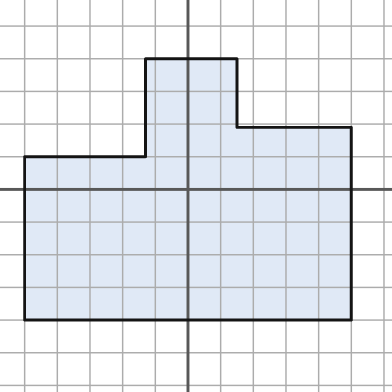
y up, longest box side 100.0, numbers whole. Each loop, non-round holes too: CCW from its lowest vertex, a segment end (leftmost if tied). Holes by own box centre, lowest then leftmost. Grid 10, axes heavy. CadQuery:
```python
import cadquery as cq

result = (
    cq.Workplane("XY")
    .moveTo(-50.0, -40.0)
    .lineTo(50.0, -40.0)
    .lineTo(50.0, 19.0)
    .lineTo(15.0, 19.0)
    .lineTo(15.0, 40.0)
    .lineTo(-13.0, 40.0)
    .lineTo(-13.0, 10.0)
    .lineTo(-50.0, 10.0)
    .close()
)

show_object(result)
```